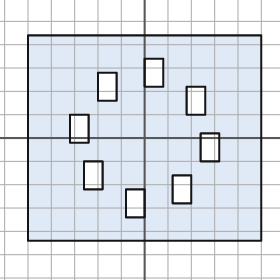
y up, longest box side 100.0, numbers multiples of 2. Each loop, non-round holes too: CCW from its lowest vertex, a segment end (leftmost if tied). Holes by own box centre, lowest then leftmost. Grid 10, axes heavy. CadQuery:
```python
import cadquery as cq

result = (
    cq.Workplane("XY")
    .moveTo(-50.0, -44.0)
    .lineTo(50.0, -44.0)
    .lineTo(50.0, 44.0)
    .lineTo(-50.0, 44.0)
    .close()
    .moveTo(-8.0, -34.0)
    .lineTo(0.0, -34.0)
    .lineTo(0.0, -22.0)
    .lineTo(-8.0, -22.0)
    .close()
    .moveTo(12.0, -28.0)
    .lineTo(20.0, -28.0)
    .lineTo(20.0, -16.0)
    .lineTo(12.0, -16.0)
    .close()
    .moveTo(-26.0, -22.0)
    .lineTo(-18.0, -22.0)
    .lineTo(-18.0, -10.0)
    .lineTo(-26.0, -10.0)
    .close()
    .moveTo(24.0, -10.0)
    .lineTo(32.0, -10.0)
    .lineTo(32.0, 2.0)
    .lineTo(24.0, 2.0)
    .close()
    .moveTo(-32.0, -2.0)
    .lineTo(-24.0, -2.0)
    .lineTo(-24.0, 10.0)
    .lineTo(-32.0, 10.0)
    .close()
    .moveTo(18.0, 10.0)
    .lineTo(26.0, 10.0)
    .lineTo(26.0, 22.0)
    .lineTo(18.0, 22.0)
    .close()
    .moveTo(-20.0, 16.0)
    .lineTo(-12.0, 16.0)
    .lineTo(-12.0, 28.0)
    .lineTo(-20.0, 28.0)
    .close()
    .moveTo(0.0, 22.0)
    .lineTo(8.0, 22.0)
    .lineTo(8.0, 34.0)
    .lineTo(0.0, 34.0)
    .close()
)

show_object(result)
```